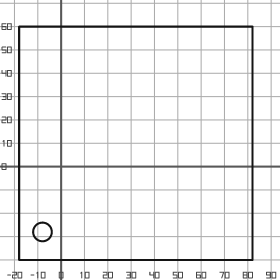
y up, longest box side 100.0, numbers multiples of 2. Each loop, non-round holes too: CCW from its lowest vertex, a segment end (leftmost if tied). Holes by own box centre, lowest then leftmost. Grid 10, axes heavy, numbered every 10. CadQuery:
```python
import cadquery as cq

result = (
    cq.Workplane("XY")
    .moveTo(-18.0, -40.0)
    .lineTo(82.0, -40.0)
    .lineTo(82.0, 60.0)
    .lineTo(-18.0, 60.0)
    .close()
    .moveTo(-8.0, -28.0)
    .circle(4.0)
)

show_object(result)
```